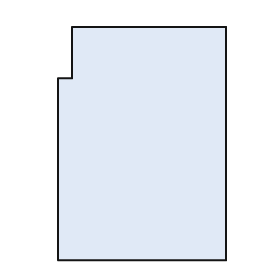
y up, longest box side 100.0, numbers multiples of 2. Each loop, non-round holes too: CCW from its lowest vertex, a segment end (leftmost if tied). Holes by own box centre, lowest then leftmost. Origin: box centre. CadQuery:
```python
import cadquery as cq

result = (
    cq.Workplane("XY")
    .moveTo(-36.0, -50.0)
    .lineTo(36.0, -50.0)
    .lineTo(36.0, 50.0)
    .lineTo(-30.0, 50.0)
    .lineTo(-30.0, 28.0)
    .lineTo(-36.0, 28.0)
    .close()
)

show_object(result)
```